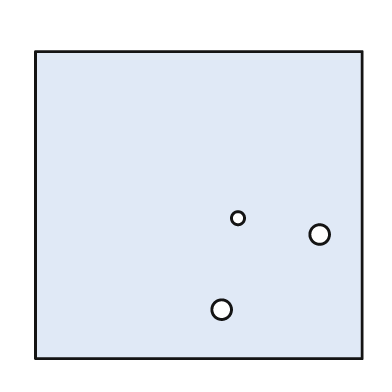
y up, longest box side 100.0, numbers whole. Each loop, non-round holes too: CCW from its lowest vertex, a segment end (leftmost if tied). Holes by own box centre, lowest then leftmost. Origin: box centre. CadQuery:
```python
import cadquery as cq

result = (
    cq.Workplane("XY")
    .moveTo(-50.0, -47.0)
    .lineTo(50.0, -47.0)
    .lineTo(50.0, 47.0)
    .lineTo(-50.0, 47.0)
    .close()
    .moveTo(7.0, -32.0)
    .circle(3.0)
    .moveTo(37.0, -9.0)
    .circle(3.0)
    .moveTo(12.0, -4.0)
    .circle(2.0)
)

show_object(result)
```